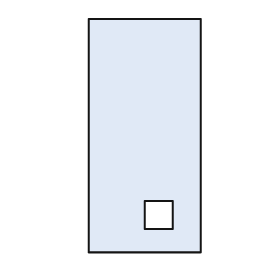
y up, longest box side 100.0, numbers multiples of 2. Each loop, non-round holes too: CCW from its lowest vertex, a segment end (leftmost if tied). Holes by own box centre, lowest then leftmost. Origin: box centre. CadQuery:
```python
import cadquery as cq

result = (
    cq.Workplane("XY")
    .moveTo(-24.0, -50.0)
    .lineTo(24.0, -50.0)
    .lineTo(24.0, 50.0)
    .lineTo(-24.0, 50.0)
    .close()
    .moveTo(0.0, -40.0)
    .lineTo(12.0, -40.0)
    .lineTo(12.0, -28.0)
    .lineTo(0.0, -28.0)
    .close()
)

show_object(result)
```